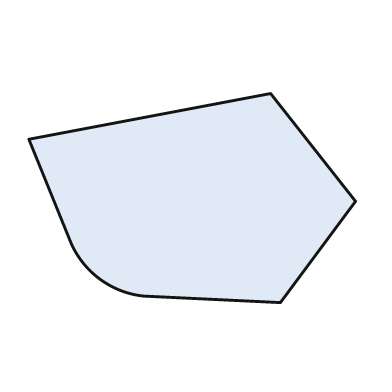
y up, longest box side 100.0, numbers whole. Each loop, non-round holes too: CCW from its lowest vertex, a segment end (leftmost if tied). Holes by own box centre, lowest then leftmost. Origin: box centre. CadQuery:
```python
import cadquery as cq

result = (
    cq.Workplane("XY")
    .moveTo(27.0, -32.0)
    .lineTo(50.0, -1.0)
    .lineTo(24.0, 32.0)
    .lineTo(-50.0, 18.0)
    .lineTo(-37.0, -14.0)
    .threePointArc((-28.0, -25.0), (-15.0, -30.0))
    .close()
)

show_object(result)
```